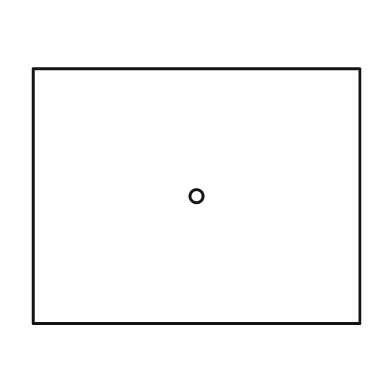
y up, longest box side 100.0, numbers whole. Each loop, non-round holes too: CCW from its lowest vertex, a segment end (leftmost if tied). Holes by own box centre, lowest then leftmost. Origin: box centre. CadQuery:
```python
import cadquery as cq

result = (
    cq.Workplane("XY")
    .moveTo(-50.0, -39.0)
    .lineTo(50.0, -39.0)
    .lineTo(50.0, 39.0)
    .lineTo(-50.0, 39.0)
    .close()
    .moveTo(0.0, 0.0)
    .circle(2.0)
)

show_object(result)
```